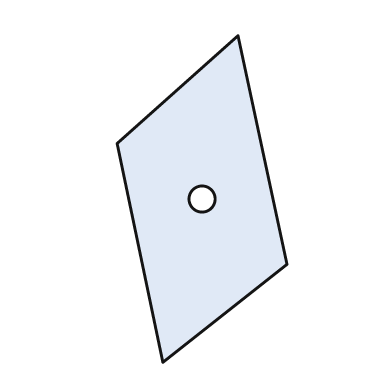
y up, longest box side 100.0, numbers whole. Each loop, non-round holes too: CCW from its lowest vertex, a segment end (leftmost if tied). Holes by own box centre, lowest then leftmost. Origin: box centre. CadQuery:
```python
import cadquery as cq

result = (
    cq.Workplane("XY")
    .moveTo(-12.0, -50.0)
    .lineTo(26.0, -20.0)
    .lineTo(11.0, 50.0)
    .lineTo(-26.0, 17.0)
    .close()
    .moveTo(0.0, 0.0)
    .circle(4.0)
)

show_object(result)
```